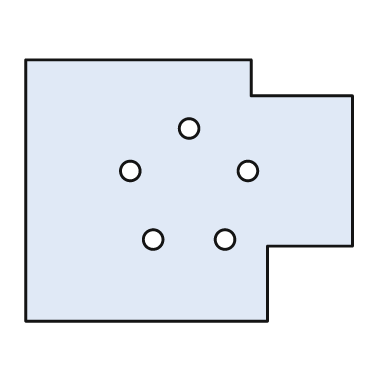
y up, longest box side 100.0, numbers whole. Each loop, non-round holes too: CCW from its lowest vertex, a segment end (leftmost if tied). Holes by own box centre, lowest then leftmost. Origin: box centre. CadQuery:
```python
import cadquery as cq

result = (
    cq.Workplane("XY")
    .moveTo(-50.0, -40.0)
    .lineTo(24.0, -40.0)
    .lineTo(24.0, -17.0)
    .lineTo(50.0, -17.0)
    .lineTo(50.0, 29.0)
    .lineTo(19.0, 29.0)
    .lineTo(19.0, 40.0)
    .lineTo(-50.0, 40.0)
    .close()
    .moveTo(-11.0, -15.0)
    .circle(3.0)
    .moveTo(11.0, -15.0)
    .circle(3.0)
    .moveTo(-18.0, 6.0)
    .circle(3.0)
    .moveTo(18.0, 6.0)
    .circle(3.0)
    .moveTo(0.0, 19.0)
    .circle(3.0)
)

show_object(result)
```